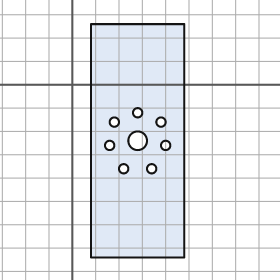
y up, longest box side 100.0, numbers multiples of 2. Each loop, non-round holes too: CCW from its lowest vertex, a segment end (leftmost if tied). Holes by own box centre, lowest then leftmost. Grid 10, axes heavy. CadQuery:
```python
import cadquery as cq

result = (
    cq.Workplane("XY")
    .moveTo(8.0, -74.0)
    .lineTo(48.0, -74.0)
    .lineTo(48.0, 26.0)
    .lineTo(8.0, 26.0)
    .close()
    .moveTo(22.0, -36.0)
    .circle(2.0)
    .moveTo(34.0, -36.0)
    .circle(2.0)
    .moveTo(16.0, -26.0)
    .circle(2.0)
    .moveTo(40.0, -26.0)
    .circle(2.0)
    .moveTo(28.0, -24.0)
    .circle(4.0)
    .moveTo(18.0, -16.0)
    .circle(2.0)
    .moveTo(38.0, -16.0)
    .circle(2.0)
    .moveTo(28.0, -12.0)
    .circle(2.0)
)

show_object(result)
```